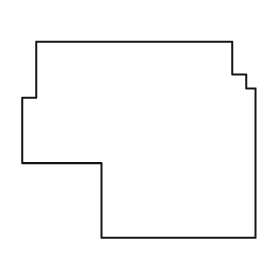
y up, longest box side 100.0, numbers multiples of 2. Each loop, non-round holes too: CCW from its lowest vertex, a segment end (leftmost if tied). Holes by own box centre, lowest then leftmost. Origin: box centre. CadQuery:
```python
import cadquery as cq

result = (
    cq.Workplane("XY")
    .moveTo(-16.0, -42.0)
    .lineTo(50.0, -42.0)
    .lineTo(50.0, 22.0)
    .lineTo(46.0, 22.0)
    .lineTo(46.0, 28.0)
    .lineTo(40.0, 28.0)
    .lineTo(40.0, 42.0)
    .lineTo(-44.0, 42.0)
    .lineTo(-44.0, 18.0)
    .lineTo(-50.0, 18.0)
    .lineTo(-50.0, -10.0)
    .lineTo(-16.0, -10.0)
    .close()
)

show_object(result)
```